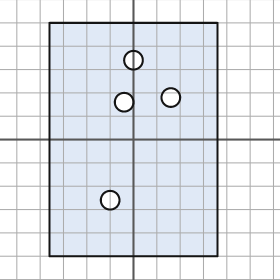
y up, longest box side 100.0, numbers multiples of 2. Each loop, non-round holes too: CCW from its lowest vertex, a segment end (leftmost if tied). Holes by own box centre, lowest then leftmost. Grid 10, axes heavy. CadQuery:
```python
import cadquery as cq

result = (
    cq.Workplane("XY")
    .moveTo(-36.0, -50.0)
    .lineTo(36.0, -50.0)
    .lineTo(36.0, 50.0)
    .lineTo(-36.0, 50.0)
    .close()
    .moveTo(-10.0, -26.0)
    .circle(4.0)
    .moveTo(-4.0, 16.0)
    .circle(4.0)
    .moveTo(16.0, 18.0)
    .circle(4.0)
    .moveTo(0.0, 34.0)
    .circle(4.0)
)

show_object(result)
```